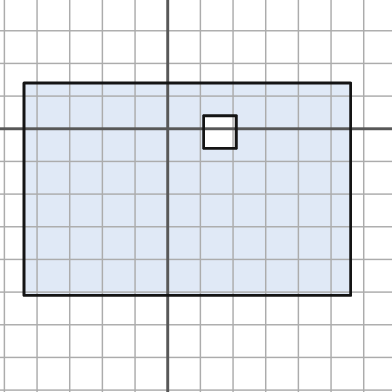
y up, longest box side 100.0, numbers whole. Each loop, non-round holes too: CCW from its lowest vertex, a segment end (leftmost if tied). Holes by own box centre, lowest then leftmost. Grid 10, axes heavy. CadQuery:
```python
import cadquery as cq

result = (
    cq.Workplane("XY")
    .moveTo(-44.0, -51.0)
    .lineTo(56.0, -51.0)
    .lineTo(56.0, 14.0)
    .lineTo(-44.0, 14.0)
    .close()
    .moveTo(11.0, -6.0)
    .lineTo(21.0, -6.0)
    .lineTo(21.0, 4.0)
    .lineTo(11.0, 4.0)
    .close()
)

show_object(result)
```